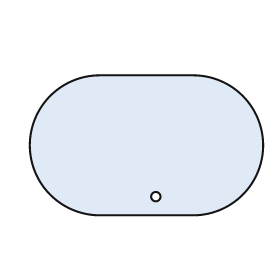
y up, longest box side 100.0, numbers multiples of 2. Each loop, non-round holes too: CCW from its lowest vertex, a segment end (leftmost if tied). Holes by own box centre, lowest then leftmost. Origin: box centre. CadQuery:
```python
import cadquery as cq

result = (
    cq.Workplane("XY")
    .moveTo(-20.0, -30.0)
    .lineTo(20.0, -30.0)
    .threePointArc((50.0, 0.0), (20.0, 30.0))
    .lineTo(-20.0, 30.0)
    .threePointArc((-50.0, 0.0), (-20.0, -30.0))
    .close()
    .moveTo(4.0, -22.0)
    .circle(2.0)
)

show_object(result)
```